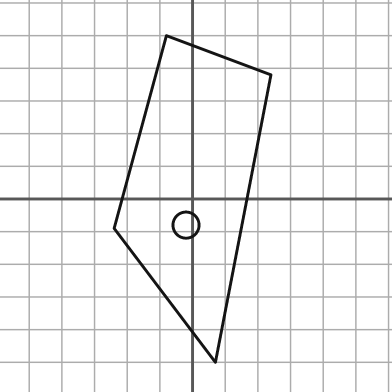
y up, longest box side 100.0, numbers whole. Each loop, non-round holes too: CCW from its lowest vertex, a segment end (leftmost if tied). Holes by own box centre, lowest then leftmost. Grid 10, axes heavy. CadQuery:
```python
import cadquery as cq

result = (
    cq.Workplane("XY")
    .moveTo(7.0, -50.0)
    .lineTo(24.0, 38.0)
    .lineTo(-8.0, 50.0)
    .lineTo(-24.0, -9.0)
    .close()
    .moveTo(-2.0, -8.0)
    .circle(4.0)
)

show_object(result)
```